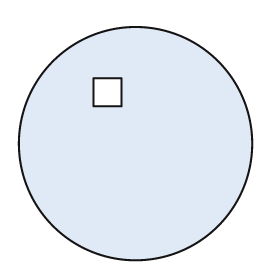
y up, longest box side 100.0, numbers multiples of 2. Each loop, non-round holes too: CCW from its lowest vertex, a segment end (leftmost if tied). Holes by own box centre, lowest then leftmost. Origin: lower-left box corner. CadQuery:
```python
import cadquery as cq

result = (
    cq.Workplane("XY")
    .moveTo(50.0, 50.0)
    .circle(50.0)
    .moveTo(32.0, 66.0)
    .lineTo(44.0, 66.0)
    .lineTo(44.0, 78.0)
    .lineTo(32.0, 78.0)
    .close()
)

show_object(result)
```